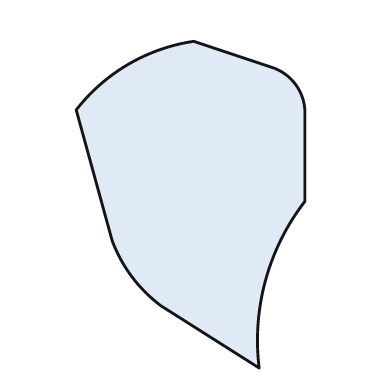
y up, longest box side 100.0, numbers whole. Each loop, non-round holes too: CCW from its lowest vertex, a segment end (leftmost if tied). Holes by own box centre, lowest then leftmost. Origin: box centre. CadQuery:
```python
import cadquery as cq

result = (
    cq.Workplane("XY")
    .moveTo(21.0, -50.0)
    .threePointArc((23.0, -23.0), (35.0, 1.0))
    .lineTo(35.0, 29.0)
    .threePointArc((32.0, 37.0), (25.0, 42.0))
    .lineTo(1.0, 50.0)
    .threePointArc((-19.0, 43.0), (-35.0, 29.0))
    .lineTo(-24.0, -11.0)
    .threePointArc((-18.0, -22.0), (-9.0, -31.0))
    .close()
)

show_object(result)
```